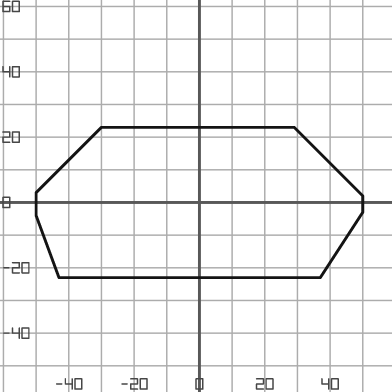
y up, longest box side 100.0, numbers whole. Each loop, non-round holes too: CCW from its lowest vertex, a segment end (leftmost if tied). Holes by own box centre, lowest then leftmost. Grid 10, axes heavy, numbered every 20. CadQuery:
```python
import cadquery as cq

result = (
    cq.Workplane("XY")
    .moveTo(-43.0, -23.0)
    .lineTo(37.0, -23.0)
    .lineTo(50.0, -3.0)
    .lineTo(50.0, 2.0)
    .lineTo(29.0, 23.0)
    .lineTo(-30.0, 23.0)
    .lineTo(-50.0, 3.0)
    .lineTo(-50.0, -4.0)
    .close()
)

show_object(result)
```